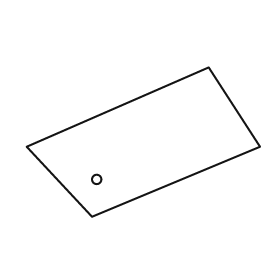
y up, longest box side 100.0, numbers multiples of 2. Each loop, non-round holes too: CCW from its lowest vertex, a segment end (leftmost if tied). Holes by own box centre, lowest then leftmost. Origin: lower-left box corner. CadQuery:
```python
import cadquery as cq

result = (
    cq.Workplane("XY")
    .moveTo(28.0, 0.0)
    .lineTo(100.0, 30.0)
    .lineTo(78.0, 64.0)
    .lineTo(0.0, 30.0)
    .close()
    .moveTo(30.0, 16.0)
    .circle(2.0)
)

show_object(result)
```